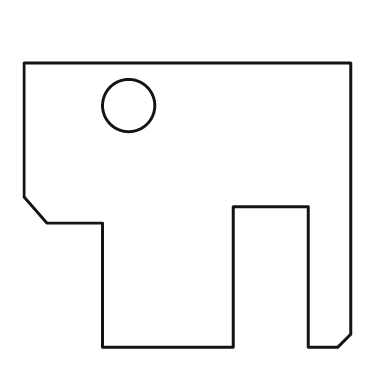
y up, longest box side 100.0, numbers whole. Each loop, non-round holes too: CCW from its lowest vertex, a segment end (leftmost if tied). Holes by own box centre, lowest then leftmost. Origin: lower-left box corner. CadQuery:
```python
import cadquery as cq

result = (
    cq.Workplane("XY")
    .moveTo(24.0, 0.0)
    .lineTo(64.0, 0.0)
    .lineTo(64.0, 43.0)
    .lineTo(87.0, 43.0)
    .lineTo(87.0, 0.0)
    .lineTo(96.0, 0.0)
    .lineTo(100.0, 4.0)
    .lineTo(100.0, 87.0)
    .lineTo(0.0, 87.0)
    .lineTo(0.0, 46.0)
    .lineTo(7.0, 38.0)
    .lineTo(24.0, 38.0)
    .close()
    .moveTo(32.0, 74.0)
    .circle(8.0)
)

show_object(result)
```